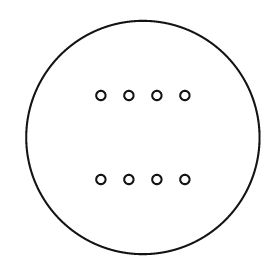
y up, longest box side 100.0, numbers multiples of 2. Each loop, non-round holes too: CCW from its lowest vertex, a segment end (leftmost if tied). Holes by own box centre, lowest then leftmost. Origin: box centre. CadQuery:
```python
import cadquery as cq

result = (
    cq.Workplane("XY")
    .moveTo(0.0, 0.0)
    .circle(50.0)
    .moveTo(-18.0, -18.0)
    .circle(2.0)
    .moveTo(-6.0, -18.0)
    .circle(2.0)
    .moveTo(6.0, -18.0)
    .circle(2.0)
    .moveTo(18.0, -18.0)
    .circle(2.0)
    .moveTo(-18.0, 18.0)
    .circle(2.0)
    .moveTo(-6.0, 18.0)
    .circle(2.0)
    .moveTo(6.0, 18.0)
    .circle(2.0)
    .moveTo(18.0, 18.0)
    .circle(2.0)
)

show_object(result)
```